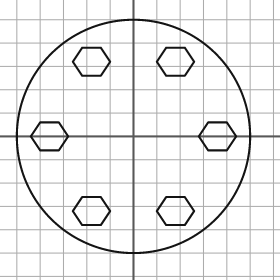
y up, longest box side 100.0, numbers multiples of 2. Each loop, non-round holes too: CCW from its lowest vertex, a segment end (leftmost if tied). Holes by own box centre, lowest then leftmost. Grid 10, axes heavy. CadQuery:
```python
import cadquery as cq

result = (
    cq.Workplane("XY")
    .moveTo(0.0, 0.0)
    .circle(50.0)
    .moveTo(-22.0, -38.0)
    .lineTo(-14.0, -38.0)
    .lineTo(-10.0, -32.0)
    .lineTo(-14.0, -26.0)
    .lineTo(-22.0, -26.0)
    .lineTo(-26.0, -32.0)
    .close()
    .moveTo(14.0, -38.0)
    .lineTo(22.0, -38.0)
    .lineTo(26.0, -32.0)
    .lineTo(22.0, -26.0)
    .lineTo(14.0, -26.0)
    .lineTo(10.0, -32.0)
    .close()
    .moveTo(-40.0, -6.0)
    .lineTo(-32.0, -6.0)
    .lineTo(-28.0, 0.0)
    .lineTo(-32.0, 6.0)
    .lineTo(-40.0, 6.0)
    .lineTo(-44.0, 0.0)
    .close()
    .moveTo(32.0, -6.0)
    .lineTo(40.0, -6.0)
    .lineTo(44.0, 0.0)
    .lineTo(40.0, 6.0)
    .lineTo(32.0, 6.0)
    .lineTo(28.0, 0.0)
    .close()
    .moveTo(-22.0, 26.0)
    .lineTo(-14.0, 26.0)
    .lineTo(-10.0, 32.0)
    .lineTo(-14.0, 38.0)
    .lineTo(-22.0, 38.0)
    .lineTo(-26.0, 32.0)
    .close()
    .moveTo(14.0, 26.0)
    .lineTo(22.0, 26.0)
    .lineTo(26.0, 32.0)
    .lineTo(22.0, 38.0)
    .lineTo(14.0, 38.0)
    .lineTo(10.0, 32.0)
    .close()
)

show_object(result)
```